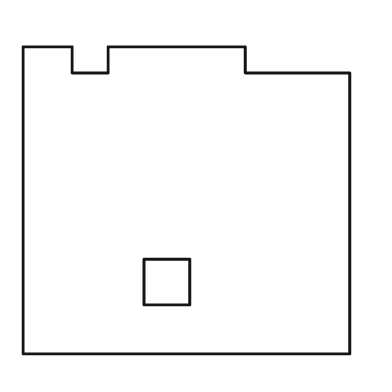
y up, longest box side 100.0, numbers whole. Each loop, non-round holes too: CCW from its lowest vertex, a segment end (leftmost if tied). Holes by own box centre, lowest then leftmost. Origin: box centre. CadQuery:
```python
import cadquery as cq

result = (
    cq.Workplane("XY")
    .moveTo(-50.0, -47.0)
    .lineTo(50.0, -47.0)
    .lineTo(50.0, 39.0)
    .lineTo(18.0, 39.0)
    .lineTo(18.0, 47.0)
    .lineTo(-24.0, 47.0)
    .lineTo(-24.0, 39.0)
    .lineTo(-35.0, 39.0)
    .lineTo(-35.0, 47.0)
    .lineTo(-50.0, 47.0)
    .close()
    .moveTo(-13.0, -32.0)
    .lineTo(1.0, -32.0)
    .lineTo(1.0, -18.0)
    .lineTo(-13.0, -18.0)
    .close()
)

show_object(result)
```